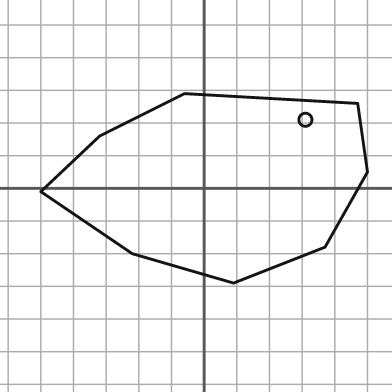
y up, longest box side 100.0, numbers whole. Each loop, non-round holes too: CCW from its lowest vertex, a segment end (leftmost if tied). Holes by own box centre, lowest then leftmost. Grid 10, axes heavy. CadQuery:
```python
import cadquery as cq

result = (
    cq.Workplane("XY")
    .moveTo(9.0, -29.0)
    .lineTo(37.0, -18.0)
    .lineTo(50.0, 5.0)
    .lineTo(47.0, 26.0)
    .lineTo(-6.0, 29.0)
    .lineTo(-32.0, 16.0)
    .lineTo(-50.0, -1.0)
    .lineTo(-22.0, -20.0)
    .close()
    .moveTo(31.0, 21.0)
    .circle(2.0)
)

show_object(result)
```